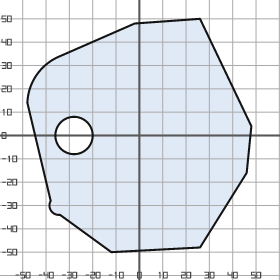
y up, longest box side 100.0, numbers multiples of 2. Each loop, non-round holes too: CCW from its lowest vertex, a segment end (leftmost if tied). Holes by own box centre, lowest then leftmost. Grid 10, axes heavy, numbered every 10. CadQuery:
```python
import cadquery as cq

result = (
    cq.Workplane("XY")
    .moveTo(-12.0, -50.0)
    .lineTo(26.0, -48.0)
    .lineTo(46.0, -16.0)
    .lineTo(48.0, 4.0)
    .lineTo(26.0, 50.0)
    .lineTo(-2.0, 48.0)
    .lineTo(-34.0, 34.0)
    .threePointArc((-44.0, 26.0), (-48.0, 14.0))
    .lineTo(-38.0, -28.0)
    .threePointArc((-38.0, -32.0), (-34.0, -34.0))
    .close()
    .moveTo(-28.0, 0.0)
    .circle(8.0)
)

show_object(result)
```